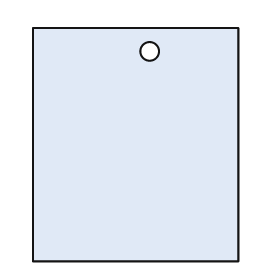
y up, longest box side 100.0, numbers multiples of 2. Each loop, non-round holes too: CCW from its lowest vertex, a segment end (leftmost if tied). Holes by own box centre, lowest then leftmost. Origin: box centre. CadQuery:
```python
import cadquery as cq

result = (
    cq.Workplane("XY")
    .moveTo(-44.0, -50.0)
    .lineTo(44.0, -50.0)
    .lineTo(44.0, 50.0)
    .lineTo(-44.0, 50.0)
    .close()
    .moveTo(6.0, 40.0)
    .circle(4.0)
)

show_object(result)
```